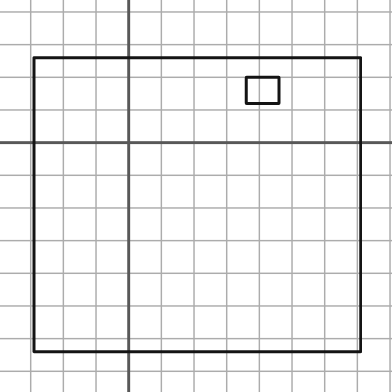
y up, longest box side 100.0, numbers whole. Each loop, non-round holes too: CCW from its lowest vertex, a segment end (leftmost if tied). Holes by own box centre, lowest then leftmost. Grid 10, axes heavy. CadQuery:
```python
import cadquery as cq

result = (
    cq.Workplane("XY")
    .moveTo(-29.0, -64.0)
    .lineTo(71.0, -64.0)
    .lineTo(71.0, 26.0)
    .lineTo(-29.0, 26.0)
    .close()
    .moveTo(36.0, 12.0)
    .lineTo(46.0, 12.0)
    .lineTo(46.0, 20.0)
    .lineTo(36.0, 20.0)
    .close()
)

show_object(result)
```